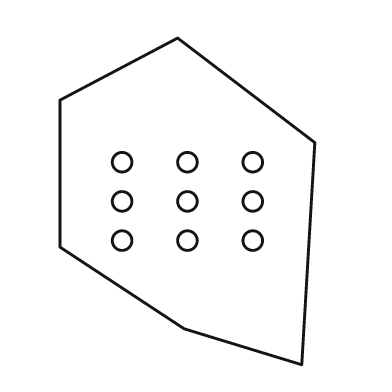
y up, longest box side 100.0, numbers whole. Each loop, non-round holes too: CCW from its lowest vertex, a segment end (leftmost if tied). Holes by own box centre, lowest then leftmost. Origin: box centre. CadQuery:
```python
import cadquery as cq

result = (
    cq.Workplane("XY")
    .moveTo(35.0, -50.0)
    .lineTo(39.0, 18.0)
    .lineTo(-3.0, 50.0)
    .lineTo(-39.0, 31.0)
    .lineTo(-39.0, -14.0)
    .lineTo(-1.0, -39.0)
    .close()
    .moveTo(-20.0, -12.0)
    .circle(3.0)
    .moveTo(0.0, -12.0)
    .circle(3.0)
    .moveTo(20.0, -12.0)
    .circle(3.0)
    .moveTo(-20.0, 0.0)
    .circle(3.0)
    .moveTo(0.0, 0.0)
    .circle(3.0)
    .moveTo(20.0, 0.0)
    .circle(3.0)
    .moveTo(-20.0, 12.0)
    .circle(3.0)
    .moveTo(0.0, 12.0)
    .circle(3.0)
    .moveTo(20.0, 12.0)
    .circle(3.0)
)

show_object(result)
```